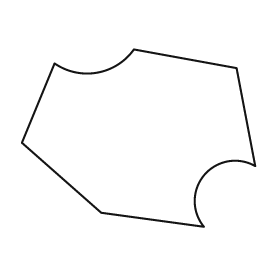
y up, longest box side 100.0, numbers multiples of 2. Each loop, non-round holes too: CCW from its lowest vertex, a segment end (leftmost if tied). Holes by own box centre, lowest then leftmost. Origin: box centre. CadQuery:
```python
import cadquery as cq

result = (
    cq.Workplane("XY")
    .moveTo(28.0, -38.0)
    .threePointArc((28.0, -16.0), (50.0, -12.0))
    .lineTo(42.0, 30.0)
    .lineTo(-2.0, 38.0)
    .threePointArc((-18.0, 28.0), (-36.0, 32.0))
    .lineTo(-50.0, -2.0)
    .lineTo(-16.0, -32.0)
    .close()
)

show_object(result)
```